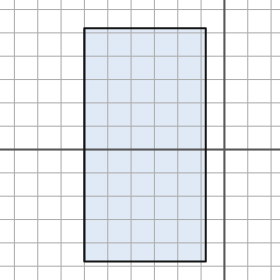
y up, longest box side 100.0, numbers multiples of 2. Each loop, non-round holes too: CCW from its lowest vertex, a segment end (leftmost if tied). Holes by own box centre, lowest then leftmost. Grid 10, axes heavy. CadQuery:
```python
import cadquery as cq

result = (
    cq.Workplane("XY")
    .moveTo(-60.0, -48.0)
    .lineTo(-8.0, -48.0)
    .lineTo(-8.0, 52.0)
    .lineTo(-60.0, 52.0)
    .close()
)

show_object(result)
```